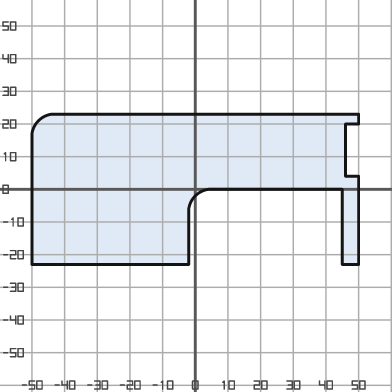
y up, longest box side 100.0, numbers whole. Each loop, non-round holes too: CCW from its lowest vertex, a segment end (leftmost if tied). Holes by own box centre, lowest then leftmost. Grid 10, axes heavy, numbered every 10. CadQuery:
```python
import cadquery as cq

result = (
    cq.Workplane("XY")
    .moveTo(-50.0, -23.0)
    .lineTo(-2.0, -23.0)
    .lineTo(-2.0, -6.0)
    .threePointArc((0.0, -2.0), (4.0, 0.0))
    .lineTo(45.0, 0.0)
    .lineTo(45.0, -23.0)
    .lineTo(50.0, -23.0)
    .lineTo(50.0, 4.0)
    .lineTo(46.0, 4.0)
    .lineTo(46.0, 20.0)
    .lineTo(50.0, 20.0)
    .lineTo(50.0, 23.0)
    .lineTo(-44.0, 23.0)
    .threePointArc((-48.0, 21.0), (-50.0, 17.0))
    .close()
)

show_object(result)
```